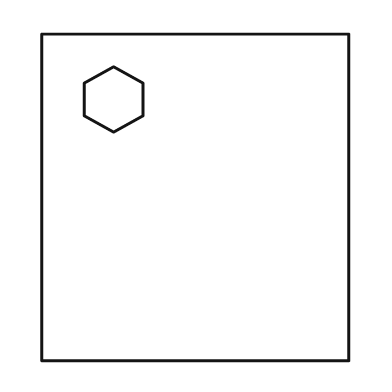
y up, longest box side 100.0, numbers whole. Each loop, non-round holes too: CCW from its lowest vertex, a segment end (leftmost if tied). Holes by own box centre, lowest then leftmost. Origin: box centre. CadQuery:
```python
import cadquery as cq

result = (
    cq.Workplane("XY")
    .moveTo(-47.0, -50.0)
    .lineTo(47.0, -50.0)
    .lineTo(47.0, 50.0)
    .lineTo(-47.0, 50.0)
    .close()
    .moveTo(-25.0, 20.0)
    .lineTo(-16.0, 25.0)
    .lineTo(-16.0, 35.0)
    .lineTo(-25.0, 40.0)
    .lineTo(-34.0, 35.0)
    .lineTo(-34.0, 25.0)
    .close()
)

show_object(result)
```